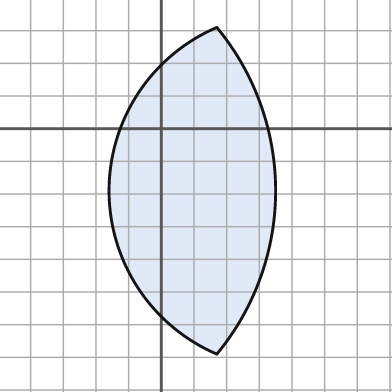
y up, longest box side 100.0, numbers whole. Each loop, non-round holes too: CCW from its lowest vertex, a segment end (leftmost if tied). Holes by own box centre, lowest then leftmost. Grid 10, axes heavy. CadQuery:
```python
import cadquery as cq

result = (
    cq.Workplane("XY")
    .moveTo(17.0, -69.0)
    .threePointArc((35.0, -19.0), (17.0, 31.0))
    .threePointArc((-16.0, -19.0), (17.0, -69.0))
    .close()
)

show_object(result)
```